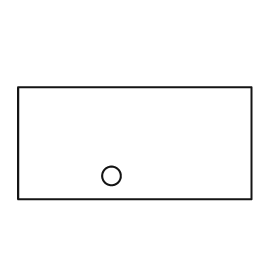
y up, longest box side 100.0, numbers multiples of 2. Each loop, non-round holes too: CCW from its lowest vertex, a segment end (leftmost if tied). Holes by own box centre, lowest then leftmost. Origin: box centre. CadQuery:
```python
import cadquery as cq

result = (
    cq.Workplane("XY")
    .moveTo(-50.0, -24.0)
    .lineTo(50.0, -24.0)
    .lineTo(50.0, 24.0)
    .lineTo(-50.0, 24.0)
    .close()
    .moveTo(-10.0, -14.0)
    .circle(4.0)
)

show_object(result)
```